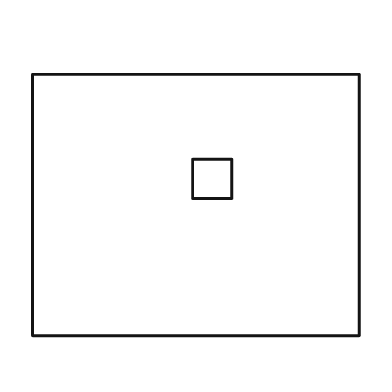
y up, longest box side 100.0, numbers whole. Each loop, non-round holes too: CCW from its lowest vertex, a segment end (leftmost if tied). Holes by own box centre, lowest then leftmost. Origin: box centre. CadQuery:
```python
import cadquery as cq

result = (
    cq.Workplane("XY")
    .moveTo(-50.0, -40.0)
    .lineTo(50.0, -40.0)
    .lineTo(50.0, 40.0)
    .lineTo(-50.0, 40.0)
    .close()
    .moveTo(-1.0, 2.0)
    .lineTo(11.0, 2.0)
    .lineTo(11.0, 14.0)
    .lineTo(-1.0, 14.0)
    .close()
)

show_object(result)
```